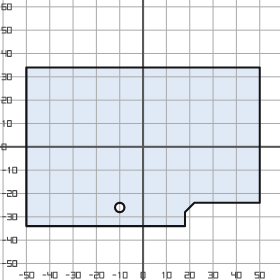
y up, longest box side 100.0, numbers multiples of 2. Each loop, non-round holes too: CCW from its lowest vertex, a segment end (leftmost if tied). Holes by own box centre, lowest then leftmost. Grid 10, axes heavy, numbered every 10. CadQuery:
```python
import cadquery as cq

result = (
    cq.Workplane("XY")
    .moveTo(-50.0, -34.0)
    .lineTo(18.0, -34.0)
    .lineTo(18.0, -28.0)
    .lineTo(22.0, -24.0)
    .lineTo(50.0, -24.0)
    .lineTo(50.0, 34.0)
    .lineTo(-50.0, 34.0)
    .close()
    .moveTo(-10.0, -26.0)
    .circle(2.0)
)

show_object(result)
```